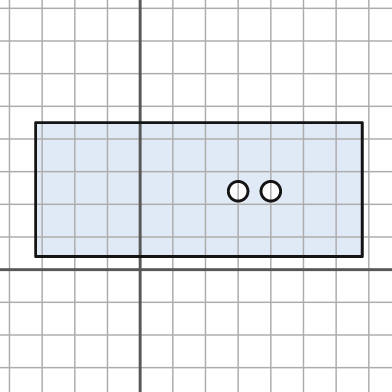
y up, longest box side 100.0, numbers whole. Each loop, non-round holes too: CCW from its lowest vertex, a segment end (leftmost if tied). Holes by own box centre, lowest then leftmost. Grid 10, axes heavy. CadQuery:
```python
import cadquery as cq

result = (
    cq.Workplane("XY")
    .moveTo(-32.0, 4.0)
    .lineTo(68.0, 4.0)
    .lineTo(68.0, 45.0)
    .lineTo(-32.0, 45.0)
    .close()
    .moveTo(30.0, 24.0)
    .circle(3.0)
    .moveTo(40.0, 24.0)
    .circle(3.0)
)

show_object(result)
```